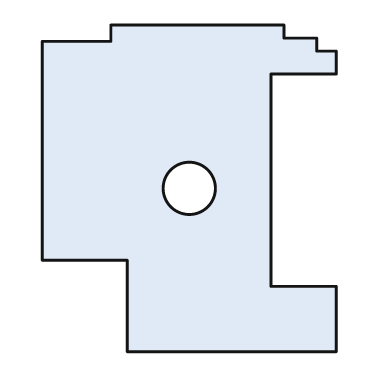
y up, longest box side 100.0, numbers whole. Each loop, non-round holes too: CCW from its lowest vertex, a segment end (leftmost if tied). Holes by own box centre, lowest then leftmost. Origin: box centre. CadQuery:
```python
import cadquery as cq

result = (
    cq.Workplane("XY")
    .moveTo(-19.0, -50.0)
    .lineTo(45.0, -50.0)
    .lineTo(45.0, -30.0)
    .lineTo(25.0, -30.0)
    .lineTo(25.0, 35.0)
    .lineTo(45.0, 35.0)
    .lineTo(45.0, 42.0)
    .lineTo(39.0, 42.0)
    .lineTo(39.0, 46.0)
    .lineTo(29.0, 46.0)
    .lineTo(29.0, 50.0)
    .lineTo(-24.0, 50.0)
    .lineTo(-24.0, 45.0)
    .lineTo(-45.0, 45.0)
    .lineTo(-45.0, -22.0)
    .lineTo(-19.0, -22.0)
    .close()
    .moveTo(0.0, 0.0)
    .circle(8.0)
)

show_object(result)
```